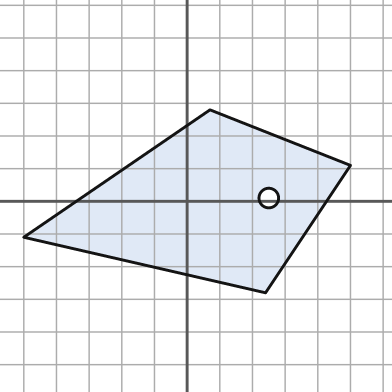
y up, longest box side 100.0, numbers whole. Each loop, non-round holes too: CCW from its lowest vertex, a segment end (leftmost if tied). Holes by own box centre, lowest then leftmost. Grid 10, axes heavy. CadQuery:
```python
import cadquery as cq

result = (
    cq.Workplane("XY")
    .moveTo(24.0, -28.0)
    .lineTo(50.0, 11.0)
    .lineTo(7.0, 28.0)
    .lineTo(-50.0, -11.0)
    .close()
    .moveTo(25.0, 1.0)
    .circle(3.0)
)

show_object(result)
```